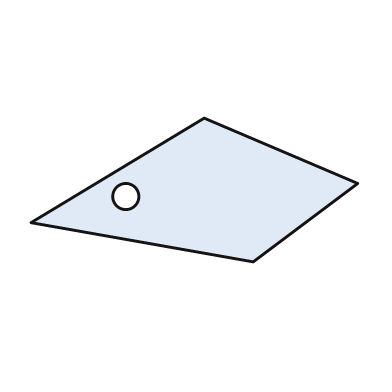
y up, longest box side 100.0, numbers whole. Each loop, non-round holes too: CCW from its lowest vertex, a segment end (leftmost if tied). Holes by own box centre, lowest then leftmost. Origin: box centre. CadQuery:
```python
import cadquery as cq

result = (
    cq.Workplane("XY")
    .moveTo(18.0, -22.0)
    .lineTo(50.0, 2.0)
    .lineTo(3.0, 22.0)
    .lineTo(-50.0, -10.0)
    .close()
    .moveTo(-21.0, -2.0)
    .circle(4.0)
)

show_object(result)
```